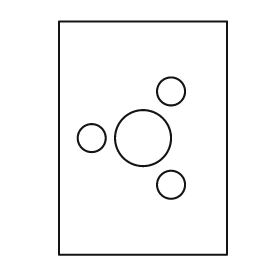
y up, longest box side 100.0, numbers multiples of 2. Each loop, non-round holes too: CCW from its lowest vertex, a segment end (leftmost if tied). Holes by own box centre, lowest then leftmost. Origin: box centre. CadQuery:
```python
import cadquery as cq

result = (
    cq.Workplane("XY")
    .moveTo(-36.0, -50.0)
    .lineTo(36.0, -50.0)
    .lineTo(36.0, 50.0)
    .lineTo(-36.0, 50.0)
    .close()
    .moveTo(12.0, -20.0)
    .circle(6.0)
    .moveTo(-22.0, 0.0)
    .circle(6.0)
    .moveTo(0.0, 0.0)
    .circle(12.0)
    .moveTo(12.0, 20.0)
    .circle(6.0)
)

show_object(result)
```